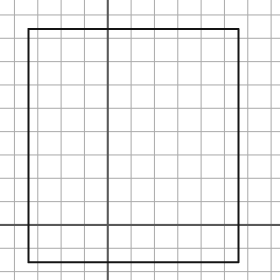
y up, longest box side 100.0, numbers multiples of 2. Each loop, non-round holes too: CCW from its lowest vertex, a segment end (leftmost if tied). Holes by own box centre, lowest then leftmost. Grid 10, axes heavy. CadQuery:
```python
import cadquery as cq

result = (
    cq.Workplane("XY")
    .moveTo(-34.0, -16.0)
    .lineTo(56.0, -16.0)
    .lineTo(56.0, 84.0)
    .lineTo(-34.0, 84.0)
    .close()
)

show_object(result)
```